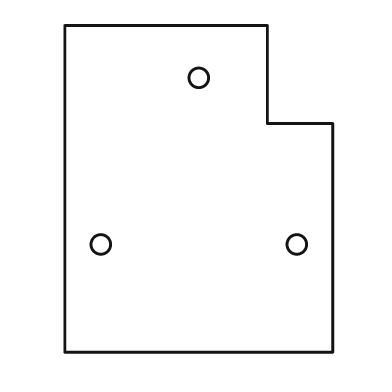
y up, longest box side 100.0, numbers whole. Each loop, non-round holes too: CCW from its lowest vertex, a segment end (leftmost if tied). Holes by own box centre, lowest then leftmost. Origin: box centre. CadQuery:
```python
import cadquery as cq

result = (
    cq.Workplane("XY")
    .moveTo(-41.0, -50.0)
    .lineTo(41.0, -50.0)
    .lineTo(41.0, 20.0)
    .lineTo(21.0, 20.0)
    .lineTo(21.0, 50.0)
    .lineTo(-41.0, 50.0)
    .close()
    .moveTo(-30.0, -17.0)
    .circle(3.0)
    .moveTo(30.0, -17.0)
    .circle(3.0)
    .moveTo(0.0, 34.0)
    .circle(3.0)
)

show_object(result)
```